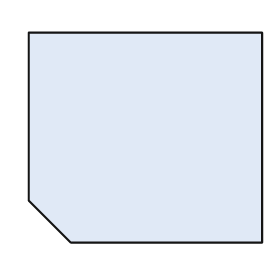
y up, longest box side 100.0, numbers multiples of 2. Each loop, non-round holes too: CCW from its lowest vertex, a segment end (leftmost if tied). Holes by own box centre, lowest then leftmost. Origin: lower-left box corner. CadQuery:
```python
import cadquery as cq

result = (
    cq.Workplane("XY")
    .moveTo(18.0, 0.0)
    .lineTo(100.0, 0.0)
    .lineTo(100.0, 90.0)
    .lineTo(0.0, 90.0)
    .lineTo(0.0, 18.0)
    .close()
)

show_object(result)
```